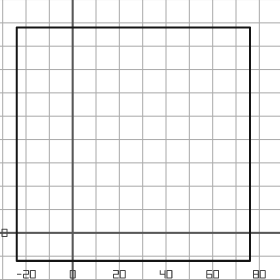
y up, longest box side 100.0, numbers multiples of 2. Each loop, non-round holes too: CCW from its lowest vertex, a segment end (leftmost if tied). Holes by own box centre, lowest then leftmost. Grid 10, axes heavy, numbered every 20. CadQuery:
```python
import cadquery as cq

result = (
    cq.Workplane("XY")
    .moveTo(-24.0, -12.0)
    .lineTo(76.0, -12.0)
    .lineTo(76.0, 88.0)
    .lineTo(-24.0, 88.0)
    .close()
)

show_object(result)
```